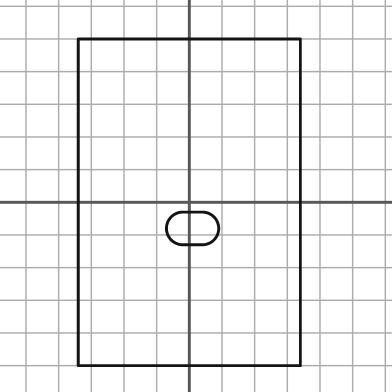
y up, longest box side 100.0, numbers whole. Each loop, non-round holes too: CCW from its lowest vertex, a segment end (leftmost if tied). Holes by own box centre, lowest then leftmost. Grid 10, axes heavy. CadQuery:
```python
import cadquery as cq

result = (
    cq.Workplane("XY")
    .moveTo(-34.0, -50.0)
    .lineTo(34.0, -50.0)
    .lineTo(34.0, 50.0)
    .lineTo(-34.0, 50.0)
    .close()
    .moveTo(-2.0, -13.0)
    .lineTo(4.0, -13.0)
    .threePointArc((9.0, -8.0), (4.0, -3.0))
    .lineTo(-2.0, -3.0)
    .threePointArc((-7.0, -8.0), (-2.0, -13.0))
    .close()
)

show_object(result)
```